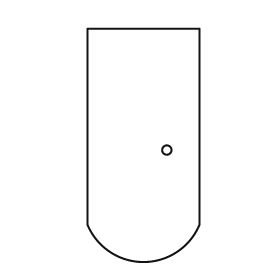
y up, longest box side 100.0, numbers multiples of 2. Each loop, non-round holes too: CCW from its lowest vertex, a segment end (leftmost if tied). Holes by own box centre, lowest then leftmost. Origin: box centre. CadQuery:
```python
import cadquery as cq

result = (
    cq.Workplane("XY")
    .moveTo(-24.0, -34.0)
    .threePointArc((0.0, -50.0), (24.0, -34.0))
    .lineTo(24.0, 50.0)
    .lineTo(-24.0, 50.0)
    .close()
    .moveTo(10.0, -2.0)
    .circle(2.0)
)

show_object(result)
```